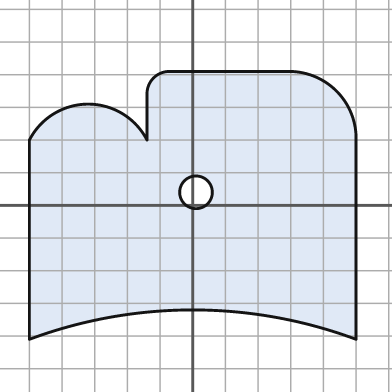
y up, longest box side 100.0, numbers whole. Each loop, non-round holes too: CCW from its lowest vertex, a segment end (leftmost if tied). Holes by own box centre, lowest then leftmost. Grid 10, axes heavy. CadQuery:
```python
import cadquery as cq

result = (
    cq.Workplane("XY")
    .moveTo(-50.0, -41.0)
    .threePointArc((0.0, -32.0), (50.0, -41.0))
    .lineTo(50.0, 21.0)
    .threePointArc((44.0, 35.0), (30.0, 41.0))
    .lineTo(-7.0, 41.0)
    .threePointArc((-12.0, 39.0), (-14.0, 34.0))
    .lineTo(-14.0, 20.0)
    .threePointArc((-32.0, 31.0), (-50.0, 20.0))
    .close()
    .moveTo(1.0, 4.0)
    .circle(5.0)
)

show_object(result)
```